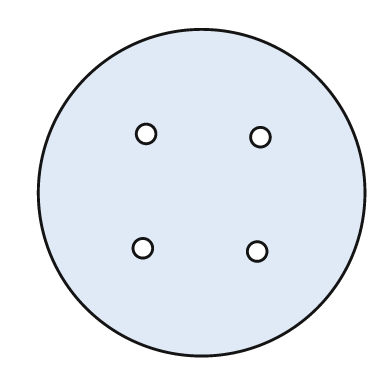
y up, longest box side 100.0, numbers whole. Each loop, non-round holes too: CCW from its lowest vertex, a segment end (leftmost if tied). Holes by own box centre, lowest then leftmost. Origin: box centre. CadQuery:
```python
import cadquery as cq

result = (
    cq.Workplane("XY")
    .moveTo(0.0, 0.0)
    .circle(50.0)
    .moveTo(17.0, -18.0)
    .circle(3.0)
    .moveTo(-18.0, -17.0)
    .circle(3.0)
    .moveTo(18.0, 17.0)
    .circle(3.0)
    .moveTo(-17.0, 18.0)
    .circle(3.0)
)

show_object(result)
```